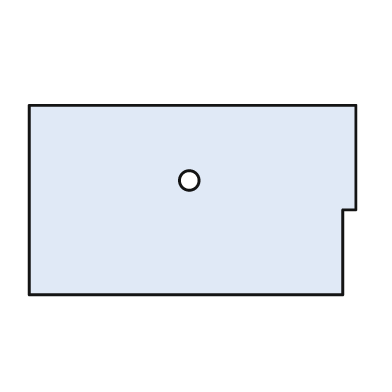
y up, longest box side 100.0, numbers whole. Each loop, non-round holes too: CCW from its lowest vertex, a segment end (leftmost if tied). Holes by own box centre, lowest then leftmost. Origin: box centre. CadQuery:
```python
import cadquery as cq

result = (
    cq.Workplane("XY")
    .moveTo(-50.0, -29.0)
    .lineTo(46.0, -29.0)
    .lineTo(46.0, -3.0)
    .lineTo(50.0, -3.0)
    .lineTo(50.0, 29.0)
    .lineTo(-50.0, 29.0)
    .close()
    .moveTo(-1.0, 6.0)
    .circle(3.0)
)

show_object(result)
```